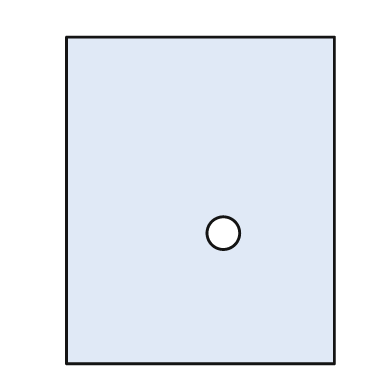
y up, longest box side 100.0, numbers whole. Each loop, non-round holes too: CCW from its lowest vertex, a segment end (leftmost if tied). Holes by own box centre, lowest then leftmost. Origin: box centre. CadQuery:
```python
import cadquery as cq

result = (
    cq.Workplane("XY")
    .moveTo(-41.0, -50.0)
    .lineTo(41.0, -50.0)
    .lineTo(41.0, 50.0)
    .lineTo(-41.0, 50.0)
    .close()
    .moveTo(7.0, -10.0)
    .circle(5.0)
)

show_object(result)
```